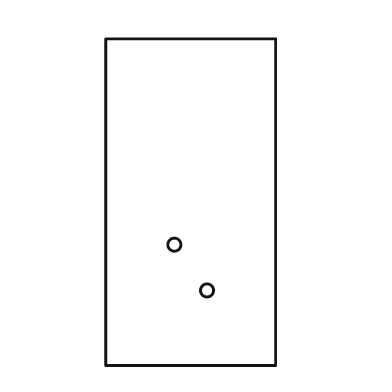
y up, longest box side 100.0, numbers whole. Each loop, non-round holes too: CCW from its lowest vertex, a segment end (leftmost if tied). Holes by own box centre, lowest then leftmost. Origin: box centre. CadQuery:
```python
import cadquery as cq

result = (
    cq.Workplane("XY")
    .moveTo(-26.0, -50.0)
    .lineTo(26.0, -50.0)
    .lineTo(26.0, 50.0)
    .lineTo(-26.0, 50.0)
    .close()
    .moveTo(5.0, -27.0)
    .circle(2.0)
    .moveTo(-5.0, -13.0)
    .circle(2.0)
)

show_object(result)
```